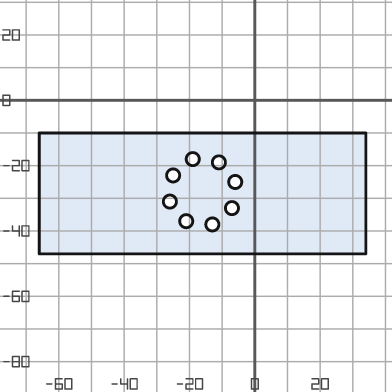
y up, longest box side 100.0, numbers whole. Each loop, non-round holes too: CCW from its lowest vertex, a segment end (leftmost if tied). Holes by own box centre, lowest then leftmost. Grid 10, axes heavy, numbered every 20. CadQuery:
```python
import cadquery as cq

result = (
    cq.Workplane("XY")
    .moveTo(-66.0, -47.0)
    .lineTo(34.0, -47.0)
    .lineTo(34.0, -10.0)
    .lineTo(-66.0, -10.0)
    .close()
    .moveTo(-13.0, -38.0)
    .circle(2.0)
    .moveTo(-21.0, -37.0)
    .circle(2.0)
    .moveTo(-7.0, -33.0)
    .circle(2.0)
    .moveTo(-26.0, -31.0)
    .circle(2.0)
    .moveTo(-6.0, -25.0)
    .circle(2.0)
    .moveTo(-25.0, -23.0)
    .circle(2.0)
    .moveTo(-11.0, -19.0)
    .circle(2.0)
    .moveTo(-19.0, -18.0)
    .circle(2.0)
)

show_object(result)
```